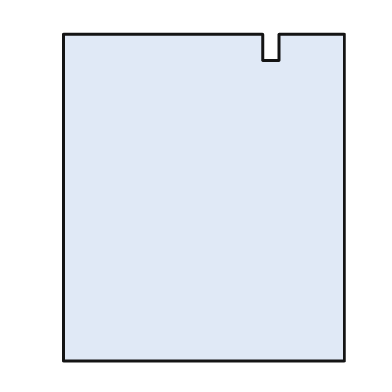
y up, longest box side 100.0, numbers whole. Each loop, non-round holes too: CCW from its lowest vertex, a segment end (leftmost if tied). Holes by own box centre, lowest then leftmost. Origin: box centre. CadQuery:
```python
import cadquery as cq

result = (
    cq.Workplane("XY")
    .moveTo(-43.0, -50.0)
    .lineTo(43.0, -50.0)
    .lineTo(43.0, 50.0)
    .lineTo(23.0, 50.0)
    .lineTo(23.0, 42.0)
    .lineTo(18.0, 42.0)
    .lineTo(18.0, 50.0)
    .lineTo(-43.0, 50.0)
    .close()
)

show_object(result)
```